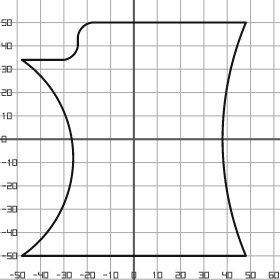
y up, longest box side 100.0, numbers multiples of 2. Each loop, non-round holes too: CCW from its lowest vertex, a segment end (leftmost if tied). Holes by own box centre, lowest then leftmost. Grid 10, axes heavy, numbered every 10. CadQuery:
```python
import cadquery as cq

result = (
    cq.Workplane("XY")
    .moveTo(-48.0, -50.0)
    .lineTo(48.0, -50.0)
    .threePointArc((38.0, 0.0), (48.0, 50.0))
    .lineTo(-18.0, 50.0)
    .threePointArc((-22.0, 48.0), (-24.0, 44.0))
    .lineTo(-24.0, 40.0)
    .threePointArc((-26.0, 36.0), (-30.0, 34.0))
    .lineTo(-48.0, 34.0)
    .threePointArc((-26.0, -8.0), (-48.0, -50.0))
    .close()
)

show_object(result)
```